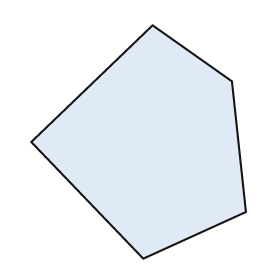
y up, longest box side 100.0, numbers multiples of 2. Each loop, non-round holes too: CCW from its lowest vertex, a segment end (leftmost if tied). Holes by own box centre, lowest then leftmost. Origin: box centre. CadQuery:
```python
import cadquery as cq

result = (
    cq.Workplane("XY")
    .moveTo(2.0, -50.0)
    .lineTo(46.0, -30.0)
    .lineTo(40.0, 26.0)
    .lineTo(6.0, 50.0)
    .lineTo(-46.0, 0.0)
    .close()
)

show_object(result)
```